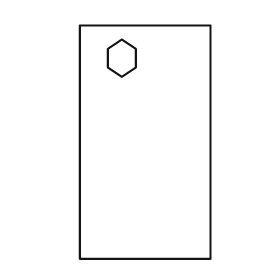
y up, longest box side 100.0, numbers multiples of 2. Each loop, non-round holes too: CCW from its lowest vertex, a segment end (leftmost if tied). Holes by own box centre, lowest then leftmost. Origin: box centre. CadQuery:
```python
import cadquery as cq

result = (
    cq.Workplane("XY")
    .moveTo(-28.0, -50.0)
    .lineTo(28.0, -50.0)
    .lineTo(28.0, 50.0)
    .lineTo(-28.0, 50.0)
    .close()
    .moveTo(-10.0, 28.0)
    .lineTo(-4.0, 32.0)
    .lineTo(-4.0, 40.0)
    .lineTo(-10.0, 44.0)
    .lineTo(-16.0, 40.0)
    .lineTo(-16.0, 32.0)
    .close()
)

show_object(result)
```